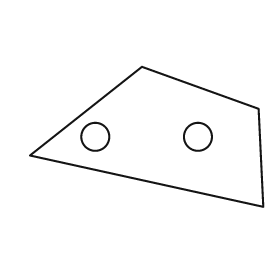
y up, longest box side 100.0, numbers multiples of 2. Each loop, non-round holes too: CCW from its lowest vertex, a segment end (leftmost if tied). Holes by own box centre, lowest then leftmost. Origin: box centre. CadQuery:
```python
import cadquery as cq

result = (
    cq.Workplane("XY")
    .moveTo(50.0, -30.0)
    .lineTo(48.0, 12.0)
    .lineTo(-2.0, 30.0)
    .lineTo(-50.0, -8.0)
    .close()
    .moveTo(-22.0, 0.0)
    .circle(6.0)
    .moveTo(22.0, 0.0)
    .circle(6.0)
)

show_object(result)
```